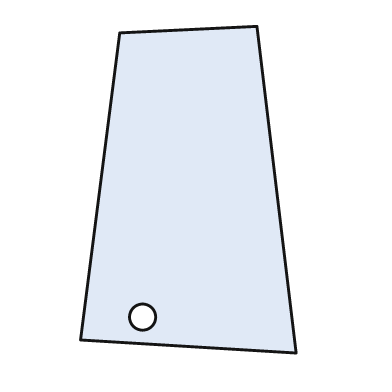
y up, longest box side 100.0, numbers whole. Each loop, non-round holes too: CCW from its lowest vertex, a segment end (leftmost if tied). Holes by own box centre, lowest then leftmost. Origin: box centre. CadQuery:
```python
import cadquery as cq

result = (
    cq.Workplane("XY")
    .moveTo(33.0, -50.0)
    .lineTo(21.0, 50.0)
    .lineTo(-21.0, 48.0)
    .lineTo(-33.0, -46.0)
    .close()
    .moveTo(-14.0, -39.0)
    .circle(4.0)
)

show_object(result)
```